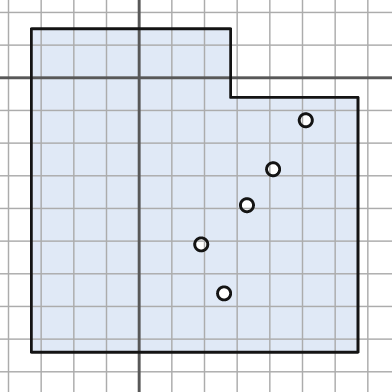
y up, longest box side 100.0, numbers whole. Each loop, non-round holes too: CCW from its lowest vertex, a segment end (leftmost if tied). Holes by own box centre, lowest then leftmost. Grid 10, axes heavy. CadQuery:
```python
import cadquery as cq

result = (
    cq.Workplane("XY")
    .moveTo(-33.0, -84.0)
    .lineTo(67.0, -84.0)
    .lineTo(67.0, -6.0)
    .lineTo(28.0, -6.0)
    .lineTo(28.0, 15.0)
    .lineTo(-33.0, 15.0)
    .close()
    .moveTo(26.0, -66.0)
    .circle(2.0)
    .moveTo(19.0, -51.0)
    .circle(2.0)
    .moveTo(33.0, -39.0)
    .circle(2.0)
    .moveTo(41.0, -28.0)
    .circle(2.0)
    .moveTo(51.0, -13.0)
    .circle(2.0)
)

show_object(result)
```